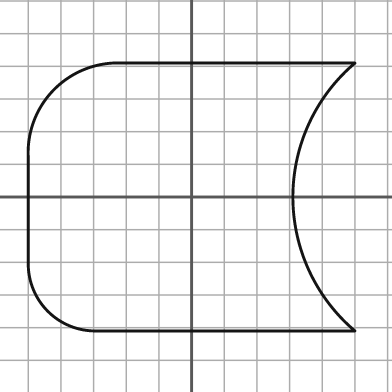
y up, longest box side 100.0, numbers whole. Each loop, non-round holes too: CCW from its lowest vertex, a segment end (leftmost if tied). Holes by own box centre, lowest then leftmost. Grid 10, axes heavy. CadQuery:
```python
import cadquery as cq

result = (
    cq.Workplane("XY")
    .moveTo(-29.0, -41.0)
    .lineTo(50.0, -41.0)
    .threePointArc((31.0, 0.0), (50.0, 41.0))
    .lineTo(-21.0, 41.0)
    .threePointArc((-42.0, 33.0), (-50.0, 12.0))
    .lineTo(-50.0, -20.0)
    .threePointArc((-44.0, -35.0), (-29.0, -41.0))
    .close()
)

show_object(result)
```